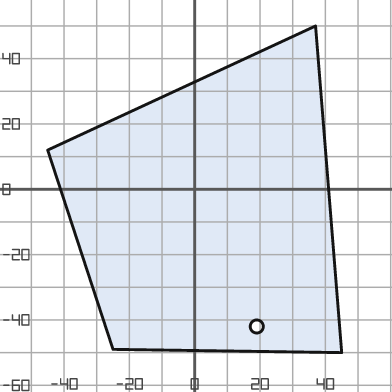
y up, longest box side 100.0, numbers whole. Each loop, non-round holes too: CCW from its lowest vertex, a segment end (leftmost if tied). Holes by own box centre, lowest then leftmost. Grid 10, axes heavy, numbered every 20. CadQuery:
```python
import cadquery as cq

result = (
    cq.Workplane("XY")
    .moveTo(45.0, -50.0)
    .lineTo(37.0, 50.0)
    .lineTo(-45.0, 12.0)
    .lineTo(-25.0, -49.0)
    .close()
    .moveTo(19.0, -42.0)
    .circle(2.0)
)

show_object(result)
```